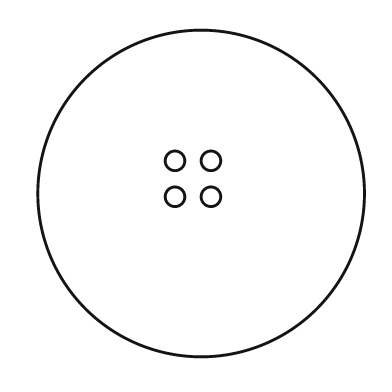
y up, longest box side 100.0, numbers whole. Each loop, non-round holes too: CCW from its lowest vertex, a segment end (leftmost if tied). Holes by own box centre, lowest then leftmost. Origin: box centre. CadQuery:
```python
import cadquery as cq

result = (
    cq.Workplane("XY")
    .moveTo(0.0, 0.0)
    .circle(50.0)
    .moveTo(-8.0, -1.0)
    .circle(3.0)
    .moveTo(3.0, -1.0)
    .circle(3.0)
    .moveTo(-8.0, 10.0)
    .circle(3.0)
    .moveTo(3.0, 10.0)
    .circle(3.0)
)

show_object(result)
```